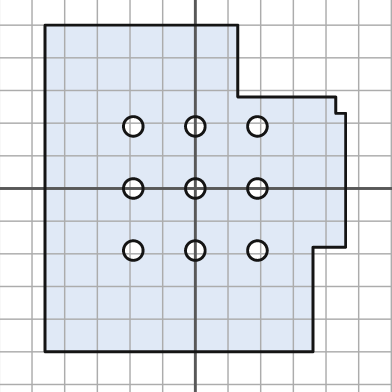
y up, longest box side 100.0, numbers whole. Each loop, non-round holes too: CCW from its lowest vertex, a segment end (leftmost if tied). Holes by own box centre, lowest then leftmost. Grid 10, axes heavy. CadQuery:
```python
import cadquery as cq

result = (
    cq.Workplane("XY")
    .moveTo(-46.0, -50.0)
    .lineTo(36.0, -50.0)
    .lineTo(36.0, -18.0)
    .lineTo(46.0, -18.0)
    .lineTo(46.0, 23.0)
    .lineTo(43.0, 23.0)
    .lineTo(43.0, 28.0)
    .lineTo(13.0, 28.0)
    .lineTo(13.0, 50.0)
    .lineTo(-46.0, 50.0)
    .close()
    .moveTo(-19.0, -19.0)
    .circle(3.0)
    .moveTo(0.0, -19.0)
    .circle(3.0)
    .moveTo(19.0, -19.0)
    .circle(3.0)
    .moveTo(-19.0, 0.0)
    .circle(3.0)
    .moveTo(0.0, 0.0)
    .circle(3.0)
    .moveTo(19.0, 0.0)
    .circle(3.0)
    .moveTo(-19.0, 19.0)
    .circle(3.0)
    .moveTo(0.0, 19.0)
    .circle(3.0)
    .moveTo(19.0, 19.0)
    .circle(3.0)
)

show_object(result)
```